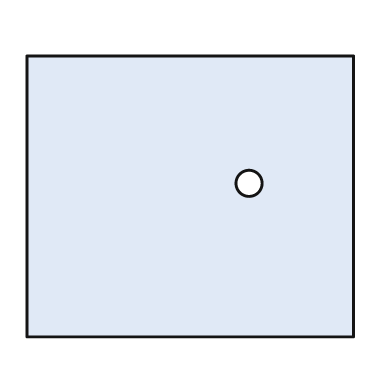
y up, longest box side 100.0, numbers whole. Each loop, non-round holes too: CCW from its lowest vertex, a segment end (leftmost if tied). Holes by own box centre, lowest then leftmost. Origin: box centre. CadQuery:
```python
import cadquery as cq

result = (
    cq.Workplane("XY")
    .moveTo(-50.0, -43.0)
    .lineTo(50.0, -43.0)
    .lineTo(50.0, 43.0)
    .lineTo(-50.0, 43.0)
    .close()
    .moveTo(18.0, 4.0)
    .circle(4.0)
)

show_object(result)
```